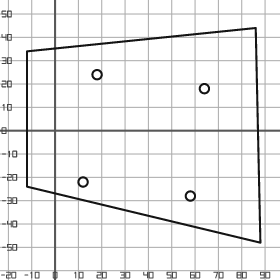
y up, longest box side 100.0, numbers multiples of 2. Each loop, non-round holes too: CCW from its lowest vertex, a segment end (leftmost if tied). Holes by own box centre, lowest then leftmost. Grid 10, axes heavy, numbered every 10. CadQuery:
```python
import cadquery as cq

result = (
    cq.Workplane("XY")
    .moveTo(88.0, -48.0)
    .lineTo(86.0, 44.0)
    .lineTo(-12.0, 34.0)
    .lineTo(-12.0, -24.0)
    .close()
    .moveTo(58.0, -28.0)
    .circle(2.0)
    .moveTo(12.0, -22.0)
    .circle(2.0)
    .moveTo(64.0, 18.0)
    .circle(2.0)
    .moveTo(18.0, 24.0)
    .circle(2.0)
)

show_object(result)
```